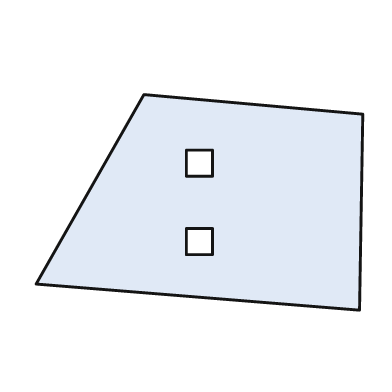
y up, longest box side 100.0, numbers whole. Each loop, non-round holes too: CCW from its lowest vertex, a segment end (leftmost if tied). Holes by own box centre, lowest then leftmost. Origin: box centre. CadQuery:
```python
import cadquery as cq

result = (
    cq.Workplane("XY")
    .moveTo(49.0, -33.0)
    .lineTo(50.0, 27.0)
    .lineTo(-17.0, 33.0)
    .lineTo(-50.0, -25.0)
    .close()
    .moveTo(-4.0, -16.0)
    .lineTo(4.0, -16.0)
    .lineTo(4.0, -8.0)
    .lineTo(-4.0, -8.0)
    .close()
    .moveTo(-4.0, 8.0)
    .lineTo(4.0, 8.0)
    .lineTo(4.0, 16.0)
    .lineTo(-4.0, 16.0)
    .close()
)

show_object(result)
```